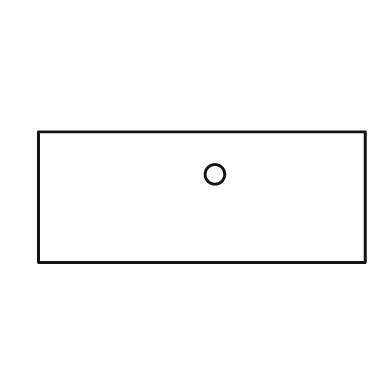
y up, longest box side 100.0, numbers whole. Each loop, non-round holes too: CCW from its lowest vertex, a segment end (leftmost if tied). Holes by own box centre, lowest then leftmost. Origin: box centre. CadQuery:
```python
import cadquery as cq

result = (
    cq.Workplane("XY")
    .moveTo(-50.0, -20.0)
    .lineTo(50.0, -20.0)
    .lineTo(50.0, 20.0)
    .lineTo(-50.0, 20.0)
    .close()
    .moveTo(4.0, 7.0)
    .circle(3.0)
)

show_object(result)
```